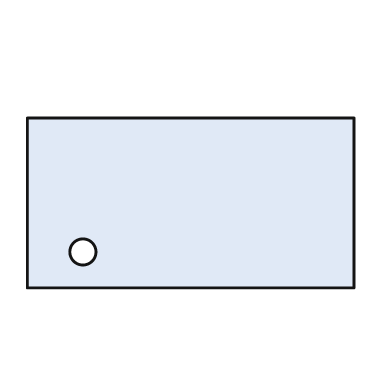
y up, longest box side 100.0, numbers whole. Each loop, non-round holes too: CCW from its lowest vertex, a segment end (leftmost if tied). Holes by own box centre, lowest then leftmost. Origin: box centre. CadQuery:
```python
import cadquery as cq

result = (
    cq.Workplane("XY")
    .moveTo(-50.0, -26.0)
    .lineTo(50.0, -26.0)
    .lineTo(50.0, 26.0)
    .lineTo(-50.0, 26.0)
    .close()
    .moveTo(-33.0, -15.0)
    .circle(4.0)
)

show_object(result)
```